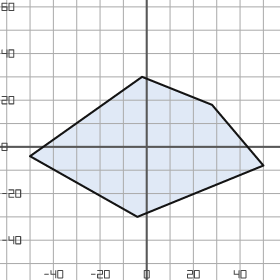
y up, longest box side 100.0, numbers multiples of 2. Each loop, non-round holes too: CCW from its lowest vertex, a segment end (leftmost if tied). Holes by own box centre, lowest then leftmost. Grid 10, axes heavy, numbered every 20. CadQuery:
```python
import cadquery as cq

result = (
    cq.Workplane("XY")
    .moveTo(-4.0, -30.0)
    .lineTo(50.0, -8.0)
    .lineTo(28.0, 18.0)
    .lineTo(-2.0, 30.0)
    .lineTo(-50.0, -4.0)
    .close()
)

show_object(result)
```